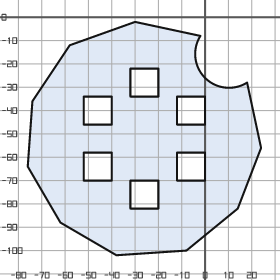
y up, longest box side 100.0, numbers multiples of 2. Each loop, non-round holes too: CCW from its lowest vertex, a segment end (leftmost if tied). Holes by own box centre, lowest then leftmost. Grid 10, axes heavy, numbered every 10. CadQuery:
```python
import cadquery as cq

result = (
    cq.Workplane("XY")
    .moveTo(-38.0, -102.0)
    .lineTo(-8.0, -100.0)
    .lineTo(14.0, -82.0)
    .lineTo(24.0, -56.0)
    .lineTo(18.0, -28.0)
    .threePointArc((0.0, -26.0), (-2.0, -8.0))
    .lineTo(-30.0, -2.0)
    .lineTo(-58.0, -12.0)
    .lineTo(-74.0, -36.0)
    .lineTo(-76.0, -64.0)
    .lineTo(-62.0, -88.0)
    .close()
    .moveTo(-32.0, -82.0)
    .lineTo(-20.0, -82.0)
    .lineTo(-20.0, -70.0)
    .lineTo(-32.0, -70.0)
    .close()
    .moveTo(-52.0, -70.0)
    .lineTo(-40.0, -70.0)
    .lineTo(-40.0, -58.0)
    .lineTo(-52.0, -58.0)
    .close()
    .moveTo(-12.0, -70.0)
    .lineTo(0.0, -70.0)
    .lineTo(0.0, -58.0)
    .lineTo(-12.0, -58.0)
    .close()
    .moveTo(-52.0, -46.0)
    .lineTo(-40.0, -46.0)
    .lineTo(-40.0, -34.0)
    .lineTo(-52.0, -34.0)
    .close()
    .moveTo(-12.0, -46.0)
    .lineTo(0.0, -46.0)
    .lineTo(0.0, -34.0)
    .lineTo(-12.0, -34.0)
    .close()
    .moveTo(-32.0, -34.0)
    .lineTo(-20.0, -34.0)
    .lineTo(-20.0, -22.0)
    .lineTo(-32.0, -22.0)
    .close()
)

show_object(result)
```